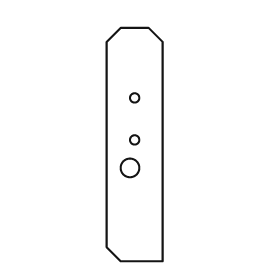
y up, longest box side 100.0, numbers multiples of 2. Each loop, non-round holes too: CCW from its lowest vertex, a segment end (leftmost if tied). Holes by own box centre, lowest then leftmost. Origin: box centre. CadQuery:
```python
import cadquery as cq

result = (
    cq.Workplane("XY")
    .moveTo(-6.0, -50.0)
    .lineTo(12.0, -50.0)
    .lineTo(12.0, 44.0)
    .lineTo(6.0, 50.0)
    .lineTo(-6.0, 50.0)
    .lineTo(-12.0, 44.0)
    .lineTo(-12.0, -44.0)
    .close()
    .moveTo(-2.0, -10.0)
    .circle(4.0)
    .moveTo(0.0, 2.0)
    .circle(2.0)
    .moveTo(0.0, 20.0)
    .circle(2.0)
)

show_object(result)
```